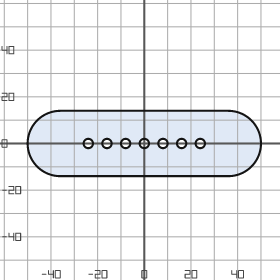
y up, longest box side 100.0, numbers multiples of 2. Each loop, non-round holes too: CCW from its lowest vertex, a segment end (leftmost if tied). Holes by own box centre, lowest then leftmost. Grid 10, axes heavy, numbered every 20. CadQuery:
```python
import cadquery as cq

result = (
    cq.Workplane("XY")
    .moveTo(-36.0, -14.0)
    .lineTo(36.0, -14.0)
    .threePointArc((50.0, 0.0), (36.0, 14.0))
    .lineTo(-36.0, 14.0)
    .threePointArc((-50.0, 0.0), (-36.0, -14.0))
    .close()
    .moveTo(-24.0, 0.0)
    .circle(2.0)
    .moveTo(-16.0, 0.0)
    .circle(2.0)
    .moveTo(-8.0, 0.0)
    .circle(2.0)
    .moveTo(0.0, 0.0)
    .circle(2.0)
    .moveTo(8.0, 0.0)
    .circle(2.0)
    .moveTo(16.0, 0.0)
    .circle(2.0)
    .moveTo(24.0, 0.0)
    .circle(2.0)
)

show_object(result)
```